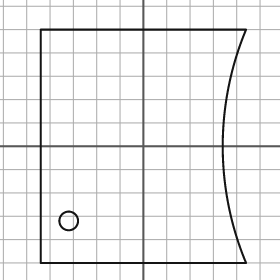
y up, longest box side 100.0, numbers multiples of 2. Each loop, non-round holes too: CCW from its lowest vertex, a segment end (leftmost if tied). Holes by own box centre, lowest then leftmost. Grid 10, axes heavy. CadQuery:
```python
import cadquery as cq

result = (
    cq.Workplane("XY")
    .moveTo(-44.0, -50.0)
    .lineTo(44.0, -50.0)
    .threePointArc((34.0, 0.0), (44.0, 50.0))
    .lineTo(-44.0, 50.0)
    .close()
    .moveTo(-32.0, -32.0)
    .circle(4.0)
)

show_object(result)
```